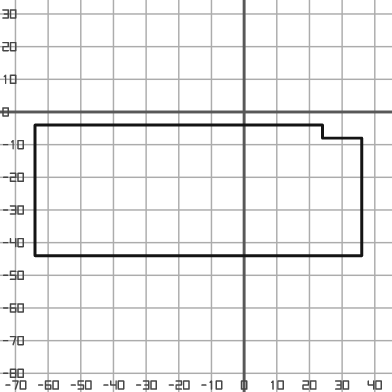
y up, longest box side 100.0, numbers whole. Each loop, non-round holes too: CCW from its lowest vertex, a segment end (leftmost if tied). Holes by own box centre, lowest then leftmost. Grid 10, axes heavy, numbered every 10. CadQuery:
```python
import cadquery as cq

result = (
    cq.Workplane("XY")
    .moveTo(-64.0, -44.0)
    .lineTo(36.0, -44.0)
    .lineTo(36.0, -8.0)
    .lineTo(24.0, -8.0)
    .lineTo(24.0, -4.0)
    .lineTo(-64.0, -4.0)
    .close()
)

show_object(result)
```